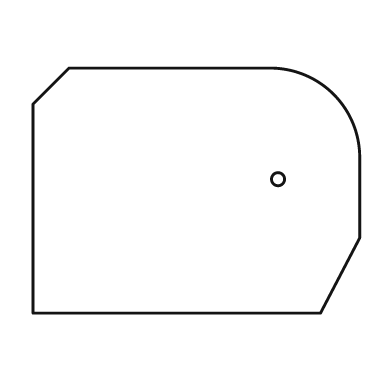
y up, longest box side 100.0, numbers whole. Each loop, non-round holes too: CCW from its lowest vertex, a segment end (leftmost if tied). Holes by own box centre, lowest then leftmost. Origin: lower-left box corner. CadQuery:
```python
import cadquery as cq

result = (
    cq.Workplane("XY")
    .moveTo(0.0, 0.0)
    .lineTo(88.0, 0.0)
    .lineTo(100.0, 23.0)
    .lineTo(100.0, 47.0)
    .threePointArc((92.0, 67.0), (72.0, 75.0))
    .lineTo(11.0, 75.0)
    .lineTo(0.0, 64.0)
    .close()
    .moveTo(75.0, 41.0)
    .circle(2.0)
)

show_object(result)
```